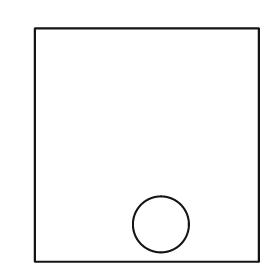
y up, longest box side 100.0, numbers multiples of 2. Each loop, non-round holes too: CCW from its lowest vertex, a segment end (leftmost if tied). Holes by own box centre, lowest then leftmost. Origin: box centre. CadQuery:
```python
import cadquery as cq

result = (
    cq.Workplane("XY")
    .moveTo(-48.0, -50.0)
    .lineTo(48.0, -50.0)
    .lineTo(48.0, 50.0)
    .lineTo(-48.0, 50.0)
    .close()
    .moveTo(6.0, -34.0)
    .circle(12.0)
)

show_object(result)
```